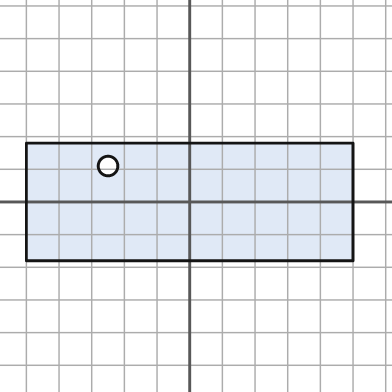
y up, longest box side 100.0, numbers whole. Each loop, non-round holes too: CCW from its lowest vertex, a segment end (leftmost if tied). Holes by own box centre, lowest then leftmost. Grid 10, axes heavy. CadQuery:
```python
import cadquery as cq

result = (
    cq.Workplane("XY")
    .moveTo(-50.0, -18.0)
    .lineTo(50.0, -18.0)
    .lineTo(50.0, 18.0)
    .lineTo(-50.0, 18.0)
    .close()
    .moveTo(-25.0, 11.0)
    .circle(3.0)
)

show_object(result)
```